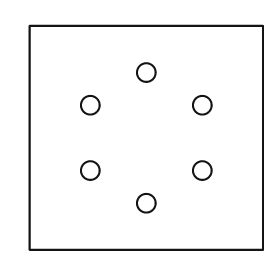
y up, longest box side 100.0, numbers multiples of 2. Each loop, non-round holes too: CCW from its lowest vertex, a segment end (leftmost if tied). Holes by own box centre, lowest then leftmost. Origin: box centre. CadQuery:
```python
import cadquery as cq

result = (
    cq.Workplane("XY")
    .moveTo(-50.0, -48.0)
    .lineTo(50.0, -48.0)
    .lineTo(50.0, 48.0)
    .lineTo(-50.0, 48.0)
    .close()
    .moveTo(0.0, -28.0)
    .circle(4.0)
    .moveTo(-24.0, -14.0)
    .circle(4.0)
    .moveTo(24.0, -14.0)
    .circle(4.0)
    .moveTo(-24.0, 14.0)
    .circle(4.0)
    .moveTo(24.0, 14.0)
    .circle(4.0)
    .moveTo(0.0, 28.0)
    .circle(4.0)
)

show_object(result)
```